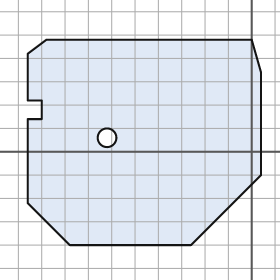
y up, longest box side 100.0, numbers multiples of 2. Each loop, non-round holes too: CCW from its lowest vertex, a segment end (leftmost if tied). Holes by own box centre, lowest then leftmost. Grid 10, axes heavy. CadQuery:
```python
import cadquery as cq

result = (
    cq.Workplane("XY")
    .moveTo(-78.0, -40.0)
    .lineTo(-26.0, -40.0)
    .lineTo(4.0, -10.0)
    .lineTo(4.0, 34.0)
    .lineTo(0.0, 48.0)
    .lineTo(-88.0, 48.0)
    .lineTo(-96.0, 42.0)
    .lineTo(-96.0, 22.0)
    .lineTo(-90.0, 22.0)
    .lineTo(-90.0, 14.0)
    .lineTo(-96.0, 14.0)
    .lineTo(-96.0, -22.0)
    .close()
    .moveTo(-62.0, 6.0)
    .circle(4.0)
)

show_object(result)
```